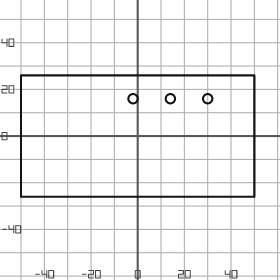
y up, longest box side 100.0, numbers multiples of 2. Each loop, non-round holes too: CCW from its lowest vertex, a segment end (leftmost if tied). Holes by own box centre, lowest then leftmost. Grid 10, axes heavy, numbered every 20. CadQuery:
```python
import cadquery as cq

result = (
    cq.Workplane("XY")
    .moveTo(-50.0, -26.0)
    .lineTo(50.0, -26.0)
    .lineTo(50.0, 26.0)
    .lineTo(-50.0, 26.0)
    .close()
    .moveTo(-2.0, 16.0)
    .circle(2.0)
    .moveTo(14.0, 16.0)
    .circle(2.0)
    .moveTo(30.0, 16.0)
    .circle(2.0)
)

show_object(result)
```